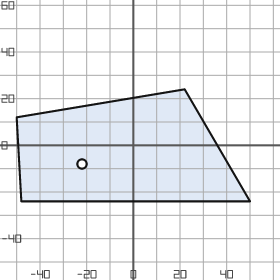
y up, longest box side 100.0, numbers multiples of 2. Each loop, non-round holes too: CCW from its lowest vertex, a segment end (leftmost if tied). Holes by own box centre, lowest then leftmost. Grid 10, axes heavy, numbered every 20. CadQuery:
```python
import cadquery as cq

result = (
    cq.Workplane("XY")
    .moveTo(-48.0, -24.0)
    .lineTo(50.0, -24.0)
    .lineTo(22.0, 24.0)
    .lineTo(-50.0, 12.0)
    .close()
    .moveTo(-22.0, -8.0)
    .circle(2.0)
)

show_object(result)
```